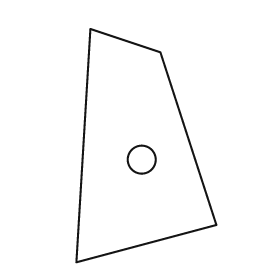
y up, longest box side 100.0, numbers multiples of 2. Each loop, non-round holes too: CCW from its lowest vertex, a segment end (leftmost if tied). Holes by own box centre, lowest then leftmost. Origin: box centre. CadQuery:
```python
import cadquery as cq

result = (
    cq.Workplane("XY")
    .moveTo(-30.0, -50.0)
    .lineTo(30.0, -34.0)
    .lineTo(6.0, 40.0)
    .lineTo(-24.0, 50.0)
    .close()
    .moveTo(-2.0, -6.0)
    .circle(6.0)
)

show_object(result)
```